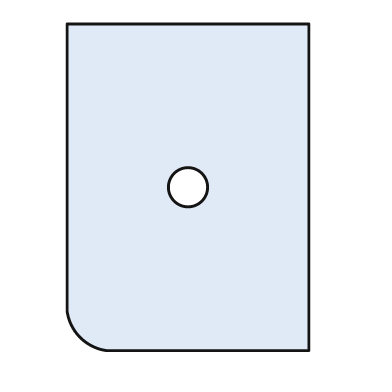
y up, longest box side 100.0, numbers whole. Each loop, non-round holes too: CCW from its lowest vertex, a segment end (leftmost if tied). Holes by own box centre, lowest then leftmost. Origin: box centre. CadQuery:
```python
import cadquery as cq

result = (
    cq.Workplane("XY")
    .moveTo(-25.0, -50.0)
    .lineTo(37.0, -50.0)
    .lineTo(37.0, 50.0)
    .lineTo(-37.0, 50.0)
    .lineTo(-37.0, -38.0)
    .threePointArc((-33.0, -46.0), (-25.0, -50.0))
    .close()
    .moveTo(0.0, 0.0)
    .circle(6.0)
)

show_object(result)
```